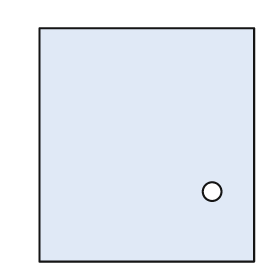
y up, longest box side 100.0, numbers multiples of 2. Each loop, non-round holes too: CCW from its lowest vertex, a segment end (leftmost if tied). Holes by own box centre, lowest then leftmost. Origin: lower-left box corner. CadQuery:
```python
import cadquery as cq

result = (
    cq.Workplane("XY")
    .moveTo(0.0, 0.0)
    .lineTo(92.0, 0.0)
    .lineTo(92.0, 100.0)
    .lineTo(0.0, 100.0)
    .close()
    .moveTo(74.0, 30.0)
    .circle(4.0)
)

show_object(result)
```